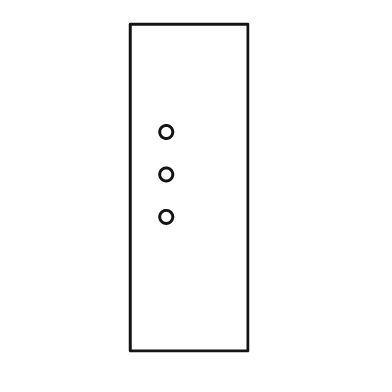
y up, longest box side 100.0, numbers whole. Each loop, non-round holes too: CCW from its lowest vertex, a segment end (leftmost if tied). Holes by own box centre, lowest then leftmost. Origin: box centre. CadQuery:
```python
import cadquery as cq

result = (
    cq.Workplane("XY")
    .moveTo(-18.0, -50.0)
    .lineTo(18.0, -50.0)
    .lineTo(18.0, 50.0)
    .lineTo(-18.0, 50.0)
    .close()
    .moveTo(-7.0, -9.0)
    .circle(2.0)
    .moveTo(-7.0, 4.0)
    .circle(2.0)
    .moveTo(-7.0, 17.0)
    .circle(2.0)
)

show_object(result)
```